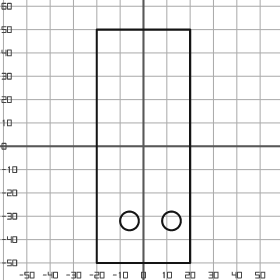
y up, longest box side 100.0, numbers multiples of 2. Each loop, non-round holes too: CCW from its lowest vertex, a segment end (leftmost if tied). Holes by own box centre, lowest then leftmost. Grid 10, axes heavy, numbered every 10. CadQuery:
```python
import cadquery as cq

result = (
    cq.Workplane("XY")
    .moveTo(-20.0, -50.0)
    .lineTo(20.0, -50.0)
    .lineTo(20.0, 50.0)
    .lineTo(-20.0, 50.0)
    .close()
    .moveTo(-6.0, -32.0)
    .circle(4.0)
    .moveTo(12.0, -32.0)
    .circle(4.0)
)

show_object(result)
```